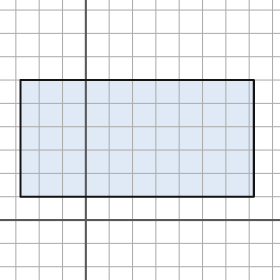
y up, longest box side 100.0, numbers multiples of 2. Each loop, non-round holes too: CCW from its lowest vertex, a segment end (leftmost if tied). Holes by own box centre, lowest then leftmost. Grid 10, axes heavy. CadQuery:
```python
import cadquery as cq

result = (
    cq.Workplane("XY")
    .moveTo(-28.0, 10.0)
    .lineTo(72.0, 10.0)
    .lineTo(72.0, 60.0)
    .lineTo(-28.0, 60.0)
    .close()
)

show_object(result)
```